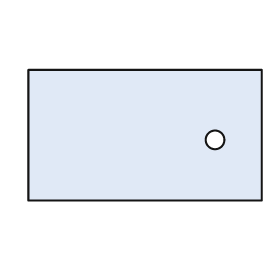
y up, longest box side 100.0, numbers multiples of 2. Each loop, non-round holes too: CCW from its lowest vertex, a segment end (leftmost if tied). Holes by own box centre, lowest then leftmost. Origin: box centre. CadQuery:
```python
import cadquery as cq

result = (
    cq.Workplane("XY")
    .moveTo(-50.0, -28.0)
    .lineTo(50.0, -28.0)
    .lineTo(50.0, 28.0)
    .lineTo(-50.0, 28.0)
    .close()
    .moveTo(30.0, -2.0)
    .circle(4.0)
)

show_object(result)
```